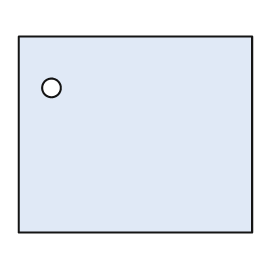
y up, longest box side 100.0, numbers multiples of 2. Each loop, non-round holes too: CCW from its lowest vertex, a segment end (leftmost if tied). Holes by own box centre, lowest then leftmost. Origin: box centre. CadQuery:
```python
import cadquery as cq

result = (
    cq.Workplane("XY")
    .moveTo(-50.0, -42.0)
    .lineTo(50.0, -42.0)
    .lineTo(50.0, 42.0)
    .lineTo(-50.0, 42.0)
    .close()
    .moveTo(-36.0, 20.0)
    .circle(4.0)
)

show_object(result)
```